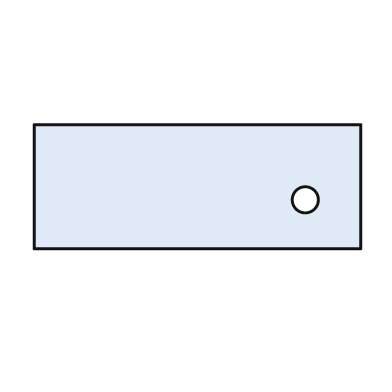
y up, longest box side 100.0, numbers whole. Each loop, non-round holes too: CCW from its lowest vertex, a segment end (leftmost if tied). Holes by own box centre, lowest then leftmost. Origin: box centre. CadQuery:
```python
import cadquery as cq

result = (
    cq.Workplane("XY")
    .moveTo(-50.0, -19.0)
    .lineTo(50.0, -19.0)
    .lineTo(50.0, 19.0)
    .lineTo(-50.0, 19.0)
    .close()
    .moveTo(33.0, -4.0)
    .circle(4.0)
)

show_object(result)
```